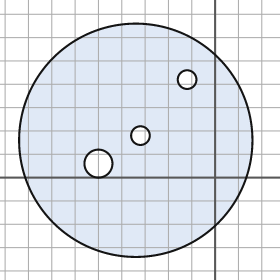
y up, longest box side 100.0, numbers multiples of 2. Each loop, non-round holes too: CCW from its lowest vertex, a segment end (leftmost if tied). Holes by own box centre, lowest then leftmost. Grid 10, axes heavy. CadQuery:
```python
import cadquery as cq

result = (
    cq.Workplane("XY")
    .moveTo(-34.0, 16.0)
    .circle(50.0)
    .moveTo(-50.0, 6.0)
    .circle(6.0)
    .moveTo(-32.0, 18.0)
    .circle(4.0)
    .moveTo(-12.0, 42.0)
    .circle(4.0)
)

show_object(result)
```